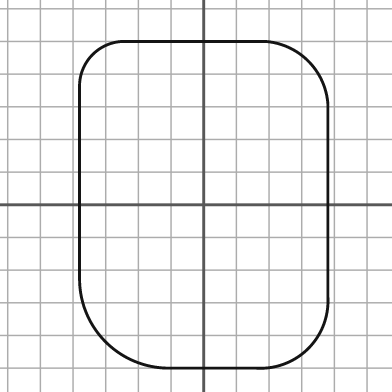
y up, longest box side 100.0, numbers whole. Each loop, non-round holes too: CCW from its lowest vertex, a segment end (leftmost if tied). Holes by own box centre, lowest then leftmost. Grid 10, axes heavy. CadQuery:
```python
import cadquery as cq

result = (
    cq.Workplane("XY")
    .moveTo(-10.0, -50.0)
    .lineTo(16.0, -50.0)
    .threePointArc((32.0, -44.0), (38.0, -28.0))
    .lineTo(38.0, 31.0)
    .threePointArc((32.0, 44.0), (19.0, 50.0))
    .lineTo(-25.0, 50.0)
    .threePointArc((-34.0, 46.0), (-38.0, 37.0))
    .lineTo(-38.0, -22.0)
    .threePointArc((-30.0, -42.0), (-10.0, -50.0))
    .close()
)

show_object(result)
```